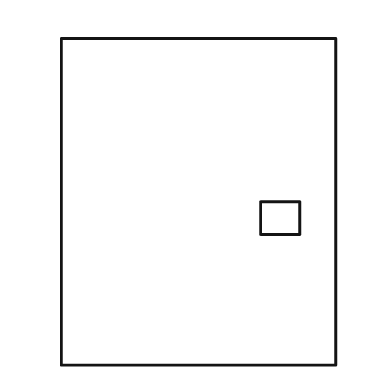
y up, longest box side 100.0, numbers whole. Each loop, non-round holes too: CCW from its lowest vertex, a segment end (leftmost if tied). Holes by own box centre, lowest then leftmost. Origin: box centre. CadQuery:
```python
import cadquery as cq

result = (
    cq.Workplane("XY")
    .moveTo(-42.0, -50.0)
    .lineTo(42.0, -50.0)
    .lineTo(42.0, 50.0)
    .lineTo(-42.0, 50.0)
    .close()
    .moveTo(19.0, -10.0)
    .lineTo(31.0, -10.0)
    .lineTo(31.0, 0.0)
    .lineTo(19.0, 0.0)
    .close()
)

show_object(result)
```